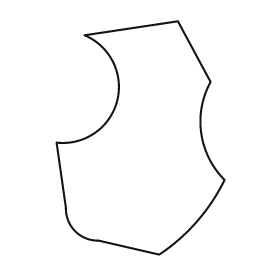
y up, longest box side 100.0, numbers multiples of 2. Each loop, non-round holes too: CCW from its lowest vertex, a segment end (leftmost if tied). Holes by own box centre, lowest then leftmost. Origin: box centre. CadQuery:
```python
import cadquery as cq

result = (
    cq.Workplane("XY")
    .moveTo(8.0, -50.0)
    .threePointArc((24.0, -36.0), (36.0, -18.0))
    .threePointArc((26.0, 2.0), (30.0, 24.0))
    .lineTo(16.0, 50.0)
    .lineTo(-24.0, 44.0)
    .threePointArc((-10.0, 16.0), (-36.0, -2.0))
    .lineTo(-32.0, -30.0)
    .threePointArc((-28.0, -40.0), (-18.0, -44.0))
    .close()
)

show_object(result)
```